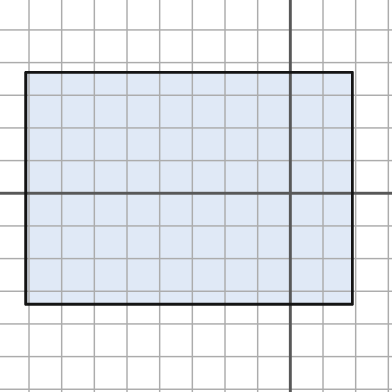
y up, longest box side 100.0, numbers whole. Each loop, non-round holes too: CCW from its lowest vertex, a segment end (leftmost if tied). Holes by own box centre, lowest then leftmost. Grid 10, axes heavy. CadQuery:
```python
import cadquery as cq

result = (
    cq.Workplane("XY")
    .moveTo(-81.0, -34.0)
    .lineTo(19.0, -34.0)
    .lineTo(19.0, 37.0)
    .lineTo(-81.0, 37.0)
    .close()
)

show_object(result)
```